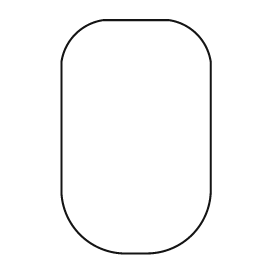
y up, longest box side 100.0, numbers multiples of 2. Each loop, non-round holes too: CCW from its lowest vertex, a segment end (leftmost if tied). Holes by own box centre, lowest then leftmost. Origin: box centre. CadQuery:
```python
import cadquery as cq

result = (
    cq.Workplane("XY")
    .moveTo(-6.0, -50.0)
    .lineTo(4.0, -50.0)
    .threePointArc((24.0, -42.0), (32.0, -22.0))
    .lineTo(32.0, 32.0)
    .threePointArc((26.0, 44.0), (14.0, 50.0))
    .lineTo(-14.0, 50.0)
    .threePointArc((-26.0, 44.0), (-32.0, 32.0))
    .lineTo(-32.0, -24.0)
    .threePointArc((-24.0, -42.0), (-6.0, -50.0))
    .close()
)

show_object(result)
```